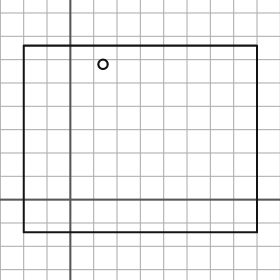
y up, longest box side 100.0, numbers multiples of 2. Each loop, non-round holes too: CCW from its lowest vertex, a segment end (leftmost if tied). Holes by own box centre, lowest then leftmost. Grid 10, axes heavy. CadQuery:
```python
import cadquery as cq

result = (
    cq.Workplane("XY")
    .moveTo(-20.0, -14.0)
    .lineTo(80.0, -14.0)
    .lineTo(80.0, 66.0)
    .lineTo(-20.0, 66.0)
    .close()
    .moveTo(14.0, 58.0)
    .circle(2.0)
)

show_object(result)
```